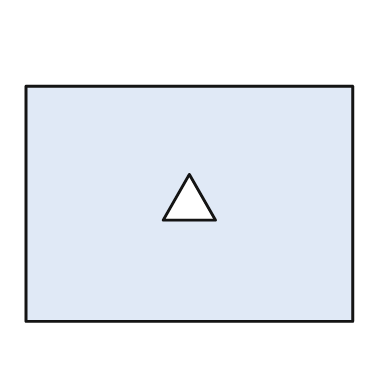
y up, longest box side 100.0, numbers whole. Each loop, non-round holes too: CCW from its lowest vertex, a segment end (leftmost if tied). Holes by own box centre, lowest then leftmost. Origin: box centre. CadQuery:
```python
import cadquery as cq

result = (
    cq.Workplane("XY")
    .moveTo(-50.0, -36.0)
    .lineTo(50.0, -36.0)
    .lineTo(50.0, 36.0)
    .lineTo(-50.0, 36.0)
    .close()
    .moveTo(-8.0, -5.0)
    .lineTo(8.0, -5.0)
    .lineTo(0.0, 9.0)
    .close()
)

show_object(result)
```